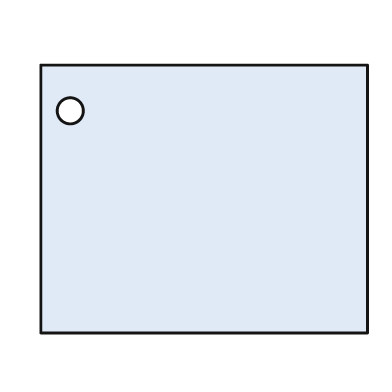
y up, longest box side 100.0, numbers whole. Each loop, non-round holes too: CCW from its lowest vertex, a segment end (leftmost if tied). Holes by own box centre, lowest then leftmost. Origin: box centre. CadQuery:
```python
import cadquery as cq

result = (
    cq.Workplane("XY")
    .moveTo(-50.0, -41.0)
    .lineTo(50.0, -41.0)
    .lineTo(50.0, 41.0)
    .lineTo(-50.0, 41.0)
    .close()
    .moveTo(-41.0, 27.0)
    .circle(4.0)
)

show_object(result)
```